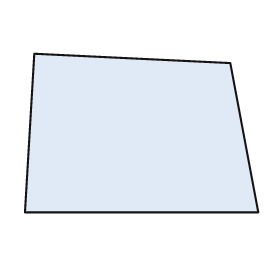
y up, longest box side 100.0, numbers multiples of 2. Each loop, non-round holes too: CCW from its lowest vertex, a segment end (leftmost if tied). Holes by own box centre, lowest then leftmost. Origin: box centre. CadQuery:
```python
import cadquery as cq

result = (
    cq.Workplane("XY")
    .moveTo(-50.0, -34.0)
    .lineTo(50.0, -34.0)
    .lineTo(38.0, 30.0)
    .lineTo(-46.0, 34.0)
    .close()
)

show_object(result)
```